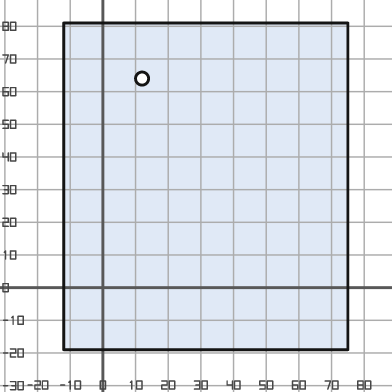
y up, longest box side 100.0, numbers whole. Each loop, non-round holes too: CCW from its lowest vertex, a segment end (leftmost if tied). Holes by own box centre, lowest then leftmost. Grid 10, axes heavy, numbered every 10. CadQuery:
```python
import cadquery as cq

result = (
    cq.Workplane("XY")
    .moveTo(-12.0, -19.0)
    .lineTo(75.0, -19.0)
    .lineTo(75.0, 81.0)
    .lineTo(-12.0, 81.0)
    .close()
    .moveTo(12.0, 64.0)
    .circle(2.0)
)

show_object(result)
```